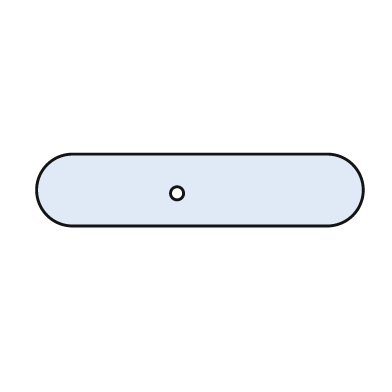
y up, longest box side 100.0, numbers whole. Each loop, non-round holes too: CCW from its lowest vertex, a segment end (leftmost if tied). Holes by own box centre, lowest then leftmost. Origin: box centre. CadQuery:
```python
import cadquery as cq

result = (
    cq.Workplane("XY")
    .moveTo(-39.0, -11.0)
    .lineTo(39.0, -11.0)
    .threePointArc((50.0, 0.0), (39.0, 11.0))
    .lineTo(-39.0, 11.0)
    .threePointArc((-50.0, 0.0), (-39.0, -11.0))
    .close()
    .moveTo(-7.0, -1.0)
    .circle(2.0)
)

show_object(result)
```